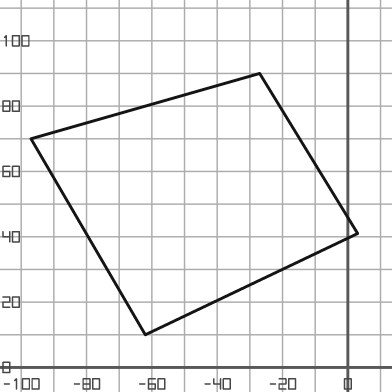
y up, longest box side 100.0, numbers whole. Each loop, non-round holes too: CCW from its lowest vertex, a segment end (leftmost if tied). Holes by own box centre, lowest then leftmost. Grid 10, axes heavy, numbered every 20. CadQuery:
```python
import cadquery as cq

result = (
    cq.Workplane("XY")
    .moveTo(-62.0, 10.0)
    .lineTo(3.0, 41.0)
    .lineTo(-27.0, 90.0)
    .lineTo(-97.0, 70.0)
    .close()
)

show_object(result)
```